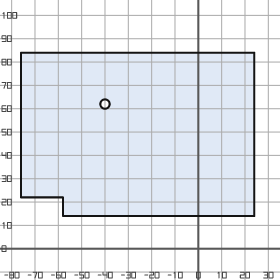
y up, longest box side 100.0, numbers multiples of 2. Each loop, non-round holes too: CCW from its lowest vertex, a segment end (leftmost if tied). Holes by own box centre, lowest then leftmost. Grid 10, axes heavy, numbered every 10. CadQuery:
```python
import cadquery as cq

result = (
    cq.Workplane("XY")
    .moveTo(-58.0, 14.0)
    .lineTo(24.0, 14.0)
    .lineTo(24.0, 84.0)
    .lineTo(-76.0, 84.0)
    .lineTo(-76.0, 22.0)
    .lineTo(-58.0, 22.0)
    .close()
    .moveTo(-40.0, 62.0)
    .circle(2.0)
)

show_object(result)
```